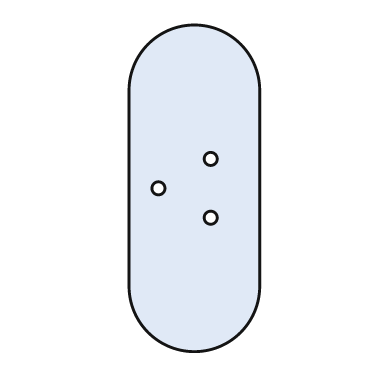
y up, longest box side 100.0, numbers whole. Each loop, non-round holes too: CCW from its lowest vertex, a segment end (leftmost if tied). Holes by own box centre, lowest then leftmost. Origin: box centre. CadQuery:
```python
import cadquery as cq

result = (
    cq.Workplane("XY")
    .moveTo(-20.0, -30.0)
    .threePointArc((0.0, -50.0), (20.0, -30.0))
    .lineTo(20.0, 30.0)
    .threePointArc((0.0, 50.0), (-20.0, 30.0))
    .close()
    .moveTo(5.0, -9.0)
    .circle(2.0)
    .moveTo(-11.0, 0.0)
    .circle(2.0)
    .moveTo(5.0, 9.0)
    .circle(2.0)
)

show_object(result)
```